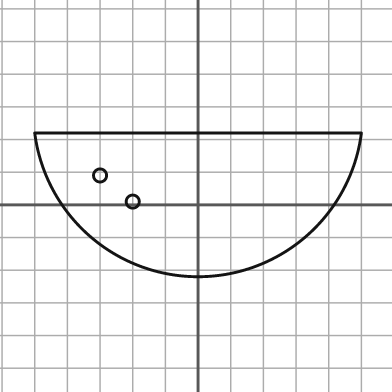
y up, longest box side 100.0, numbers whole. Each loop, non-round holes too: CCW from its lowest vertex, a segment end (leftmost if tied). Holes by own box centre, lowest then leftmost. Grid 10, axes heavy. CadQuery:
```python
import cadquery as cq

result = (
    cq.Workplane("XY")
    .moveTo(-50.0, 22.0)
    .threePointArc((0.0, -22.0), (50.0, 22.0))
    .close()
    .moveTo(-20.0, 1.0)
    .circle(2.0)
    .moveTo(-30.0, 9.0)
    .circle(2.0)
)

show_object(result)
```